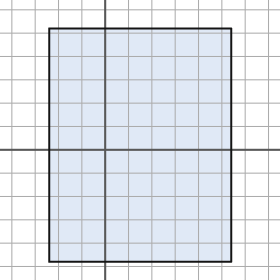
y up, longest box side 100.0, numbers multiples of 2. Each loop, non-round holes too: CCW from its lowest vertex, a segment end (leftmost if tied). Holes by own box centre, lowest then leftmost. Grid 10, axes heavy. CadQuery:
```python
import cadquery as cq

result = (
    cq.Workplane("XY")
    .moveTo(-24.0, -48.0)
    .lineTo(54.0, -48.0)
    .lineTo(54.0, 52.0)
    .lineTo(-24.0, 52.0)
    .close()
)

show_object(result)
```